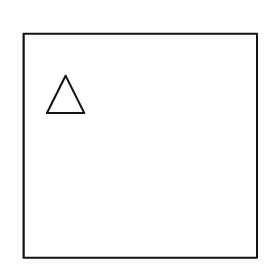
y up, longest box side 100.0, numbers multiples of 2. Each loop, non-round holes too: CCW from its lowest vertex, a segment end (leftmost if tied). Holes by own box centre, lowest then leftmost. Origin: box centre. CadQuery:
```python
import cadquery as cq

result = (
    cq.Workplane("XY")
    .moveTo(-50.0, -48.0)
    .lineTo(50.0, -48.0)
    .lineTo(50.0, 48.0)
    .lineTo(-50.0, 48.0)
    .close()
    .moveTo(-40.0, 14.0)
    .lineTo(-24.0, 14.0)
    .lineTo(-32.0, 30.0)
    .close()
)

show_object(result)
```